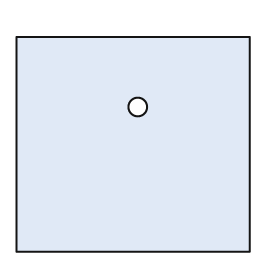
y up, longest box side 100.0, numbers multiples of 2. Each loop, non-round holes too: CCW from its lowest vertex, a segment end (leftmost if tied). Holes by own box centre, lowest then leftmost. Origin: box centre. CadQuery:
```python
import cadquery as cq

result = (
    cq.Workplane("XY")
    .moveTo(-50.0, -46.0)
    .lineTo(50.0, -46.0)
    .lineTo(50.0, 46.0)
    .lineTo(-50.0, 46.0)
    .close()
    .moveTo(2.0, 16.0)
    .circle(4.0)
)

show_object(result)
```